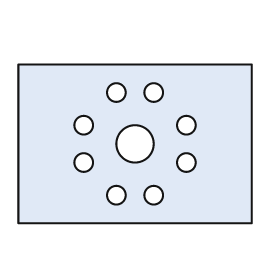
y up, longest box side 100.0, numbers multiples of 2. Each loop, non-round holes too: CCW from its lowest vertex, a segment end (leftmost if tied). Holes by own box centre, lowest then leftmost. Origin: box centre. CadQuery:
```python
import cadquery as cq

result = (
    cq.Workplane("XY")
    .moveTo(-50.0, -34.0)
    .lineTo(50.0, -34.0)
    .lineTo(50.0, 34.0)
    .lineTo(-50.0, 34.0)
    .close()
    .moveTo(-8.0, -22.0)
    .circle(4.0)
    .moveTo(8.0, -22.0)
    .circle(4.0)
    .moveTo(-22.0, -8.0)
    .circle(4.0)
    .moveTo(22.0, -8.0)
    .circle(4.0)
    .moveTo(0.0, 0.0)
    .circle(8.0)
    .moveTo(-22.0, 8.0)
    .circle(4.0)
    .moveTo(22.0, 8.0)
    .circle(4.0)
    .moveTo(-8.0, 22.0)
    .circle(4.0)
    .moveTo(8.0, 22.0)
    .circle(4.0)
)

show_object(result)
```